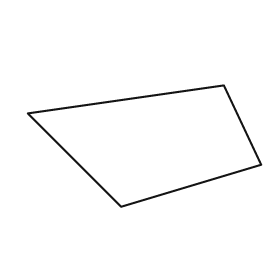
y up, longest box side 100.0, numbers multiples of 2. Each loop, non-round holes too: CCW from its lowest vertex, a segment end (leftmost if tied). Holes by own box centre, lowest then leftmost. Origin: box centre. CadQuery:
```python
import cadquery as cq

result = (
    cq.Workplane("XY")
    .moveTo(-10.0, -26.0)
    .lineTo(50.0, -8.0)
    .lineTo(34.0, 26.0)
    .lineTo(-50.0, 14.0)
    .close()
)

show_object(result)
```